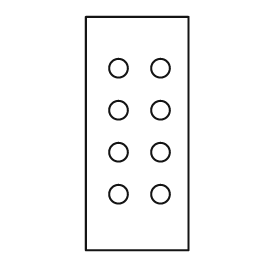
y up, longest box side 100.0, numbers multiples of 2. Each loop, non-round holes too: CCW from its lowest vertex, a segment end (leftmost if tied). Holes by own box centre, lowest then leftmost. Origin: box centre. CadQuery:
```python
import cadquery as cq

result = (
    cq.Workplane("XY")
    .moveTo(-22.0, -50.0)
    .lineTo(22.0, -50.0)
    .lineTo(22.0, 50.0)
    .lineTo(-22.0, 50.0)
    .close()
    .moveTo(-8.0, -26.0)
    .circle(4.0)
    .moveTo(10.0, -26.0)
    .circle(4.0)
    .moveTo(-8.0, -8.0)
    .circle(4.0)
    .moveTo(10.0, -8.0)
    .circle(4.0)
    .moveTo(-8.0, 10.0)
    .circle(4.0)
    .moveTo(10.0, 10.0)
    .circle(4.0)
    .moveTo(-8.0, 28.0)
    .circle(4.0)
    .moveTo(10.0, 28.0)
    .circle(4.0)
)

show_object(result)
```